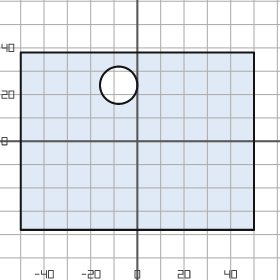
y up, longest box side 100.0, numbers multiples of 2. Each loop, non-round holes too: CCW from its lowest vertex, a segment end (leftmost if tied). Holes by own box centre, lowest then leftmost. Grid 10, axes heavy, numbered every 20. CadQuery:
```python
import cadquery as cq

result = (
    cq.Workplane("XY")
    .moveTo(-50.0, -38.0)
    .lineTo(50.0, -38.0)
    .lineTo(50.0, 38.0)
    .lineTo(-50.0, 38.0)
    .close()
    .moveTo(-8.0, 24.0)
    .circle(8.0)
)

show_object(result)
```